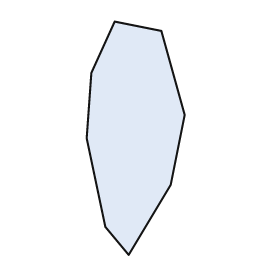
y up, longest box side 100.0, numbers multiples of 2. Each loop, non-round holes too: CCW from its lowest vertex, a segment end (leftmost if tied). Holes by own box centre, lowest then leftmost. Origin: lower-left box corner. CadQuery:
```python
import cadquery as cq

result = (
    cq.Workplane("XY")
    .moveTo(18.0, 0.0)
    .lineTo(36.0, 30.0)
    .lineTo(42.0, 60.0)
    .lineTo(32.0, 96.0)
    .lineTo(12.0, 100.0)
    .lineTo(2.0, 78.0)
    .lineTo(0.0, 50.0)
    .lineTo(8.0, 12.0)
    .close()
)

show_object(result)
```